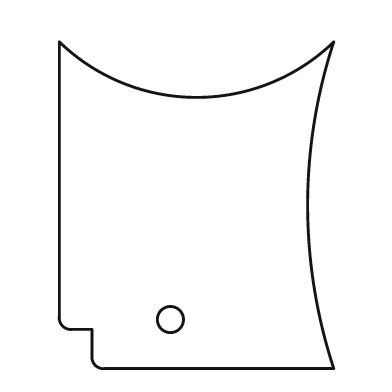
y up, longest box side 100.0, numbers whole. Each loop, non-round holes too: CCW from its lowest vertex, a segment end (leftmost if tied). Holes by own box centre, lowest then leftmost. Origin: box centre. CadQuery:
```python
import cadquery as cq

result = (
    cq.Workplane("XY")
    .moveTo(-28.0, -50.0)
    .lineTo(42.0, -50.0)
    .threePointArc((34.0, 0.0), (42.0, 50.0))
    .threePointArc((0.0, 33.0), (-42.0, 50.0))
    .lineTo(-42.0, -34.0)
    .threePointArc((-41.0, -37.0), (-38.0, -38.0))
    .lineTo(-32.0, -38.0)
    .lineTo(-32.0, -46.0)
    .threePointArc((-31.0, -49.0), (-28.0, -50.0))
    .close()
    .moveTo(-8.0, -35.0)
    .circle(4.0)
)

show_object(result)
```